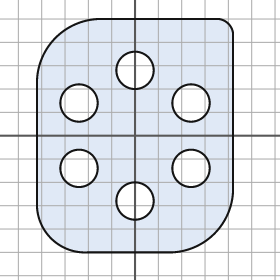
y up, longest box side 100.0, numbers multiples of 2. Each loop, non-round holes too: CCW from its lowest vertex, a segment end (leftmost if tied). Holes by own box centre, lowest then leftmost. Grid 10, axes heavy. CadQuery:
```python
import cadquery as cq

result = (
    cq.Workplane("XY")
    .moveTo(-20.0, -50.0)
    .lineTo(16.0, -50.0)
    .threePointArc((34.0, -42.0), (42.0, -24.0))
    .lineTo(42.0, 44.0)
    .threePointArc((40.0, 48.0), (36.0, 50.0))
    .lineTo(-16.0, 50.0)
    .threePointArc((-34.0, 42.0), (-42.0, 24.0))
    .lineTo(-42.0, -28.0)
    .threePointArc((-36.0, -44.0), (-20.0, -50.0))
    .close()
    .moveTo(0.0, -28.0)
    .circle(8.0)
    .moveTo(-24.0, -14.0)
    .circle(8.0)
    .moveTo(24.0, -14.0)
    .circle(8.0)
    .moveTo(-24.0, 14.0)
    .circle(8.0)
    .moveTo(24.0, 14.0)
    .circle(8.0)
    .moveTo(0.0, 28.0)
    .circle(8.0)
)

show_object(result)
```